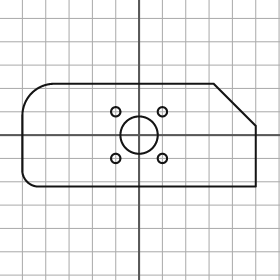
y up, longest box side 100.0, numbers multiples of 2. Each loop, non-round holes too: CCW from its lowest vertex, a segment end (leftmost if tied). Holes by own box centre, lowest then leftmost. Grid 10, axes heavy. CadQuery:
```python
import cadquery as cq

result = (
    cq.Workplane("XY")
    .moveTo(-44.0, -22.0)
    .lineTo(50.0, -22.0)
    .lineTo(50.0, 4.0)
    .lineTo(32.0, 22.0)
    .lineTo(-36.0, 22.0)
    .threePointArc((-46.0, 18.0), (-50.0, 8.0))
    .lineTo(-50.0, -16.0)
    .threePointArc((-48.0, -20.0), (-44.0, -22.0))
    .close()
    .moveTo(-10.0, -10.0)
    .circle(2.0)
    .moveTo(10.0, -10.0)
    .circle(2.0)
    .moveTo(0.0, 0.0)
    .circle(8.0)
    .moveTo(-10.0, 10.0)
    .circle(2.0)
    .moveTo(10.0, 10.0)
    .circle(2.0)
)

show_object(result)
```